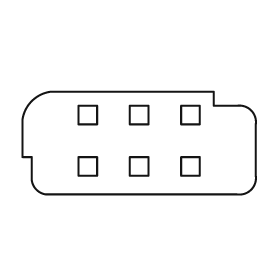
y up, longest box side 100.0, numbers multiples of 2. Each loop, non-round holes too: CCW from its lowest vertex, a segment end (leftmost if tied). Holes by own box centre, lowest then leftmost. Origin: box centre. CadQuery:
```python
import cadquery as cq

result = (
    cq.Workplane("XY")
    .moveTo(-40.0, -22.0)
    .lineTo(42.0, -22.0)
    .threePointArc((48.0, -20.0), (50.0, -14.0))
    .lineTo(50.0, 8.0)
    .threePointArc((48.0, 14.0), (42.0, 16.0))
    .lineTo(32.0, 16.0)
    .lineTo(32.0, 22.0)
    .lineTo(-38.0, 22.0)
    .threePointArc((-46.0, 18.0), (-50.0, 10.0))
    .lineTo(-50.0, -6.0)
    .lineTo(-46.0, -6.0)
    .lineTo(-46.0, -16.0)
    .threePointArc((-44.0, -20.0), (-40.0, -22.0))
    .close()
    .moveTo(-26.0, -14.0)
    .lineTo(-18.0, -14.0)
    .lineTo(-18.0, -6.0)
    .lineTo(-26.0, -6.0)
    .close()
    .moveTo(-4.0, -14.0)
    .lineTo(4.0, -14.0)
    .lineTo(4.0, -6.0)
    .lineTo(-4.0, -6.0)
    .close()
    .moveTo(18.0, -14.0)
    .lineTo(26.0, -14.0)
    .lineTo(26.0, -6.0)
    .lineTo(18.0, -6.0)
    .close()
    .moveTo(-26.0, 8.0)
    .lineTo(-18.0, 8.0)
    .lineTo(-18.0, 16.0)
    .lineTo(-26.0, 16.0)
    .close()
    .moveTo(-4.0, 8.0)
    .lineTo(4.0, 8.0)
    .lineTo(4.0, 16.0)
    .lineTo(-4.0, 16.0)
    .close()
    .moveTo(18.0, 8.0)
    .lineTo(26.0, 8.0)
    .lineTo(26.0, 16.0)
    .lineTo(18.0, 16.0)
    .close()
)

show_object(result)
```